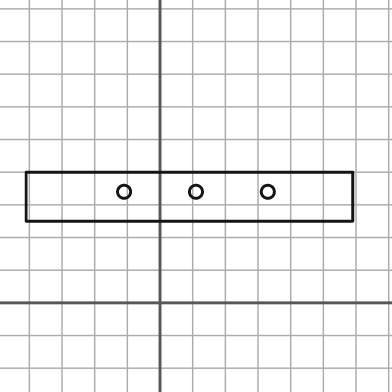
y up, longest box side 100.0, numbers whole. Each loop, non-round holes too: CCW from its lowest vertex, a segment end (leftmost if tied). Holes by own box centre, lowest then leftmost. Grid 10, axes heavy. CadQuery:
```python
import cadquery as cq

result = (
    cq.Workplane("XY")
    .moveTo(-41.0, 25.0)
    .lineTo(59.0, 25.0)
    .lineTo(59.0, 40.0)
    .lineTo(-41.0, 40.0)
    .close()
    .moveTo(-11.0, 34.0)
    .circle(2.0)
    .moveTo(11.0, 34.0)
    .circle(2.0)
    .moveTo(33.0, 34.0)
    .circle(2.0)
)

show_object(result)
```